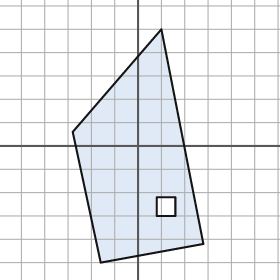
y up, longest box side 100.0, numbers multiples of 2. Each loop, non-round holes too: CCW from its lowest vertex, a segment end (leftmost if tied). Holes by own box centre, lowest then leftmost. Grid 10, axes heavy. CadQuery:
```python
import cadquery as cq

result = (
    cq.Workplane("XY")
    .moveTo(-16.0, -50.0)
    .lineTo(28.0, -42.0)
    .lineTo(10.0, 50.0)
    .lineTo(-28.0, 6.0)
    .close()
    .moveTo(8.0, -30.0)
    .lineTo(16.0, -30.0)
    .lineTo(16.0, -22.0)
    .lineTo(8.0, -22.0)
    .close()
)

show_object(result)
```